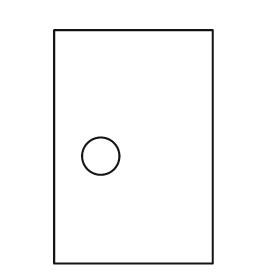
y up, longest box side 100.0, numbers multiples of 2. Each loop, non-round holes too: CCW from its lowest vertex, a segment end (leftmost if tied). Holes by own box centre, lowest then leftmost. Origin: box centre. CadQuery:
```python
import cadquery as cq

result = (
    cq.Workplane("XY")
    .moveTo(-34.0, -50.0)
    .lineTo(34.0, -50.0)
    .lineTo(34.0, 50.0)
    .lineTo(-34.0, 50.0)
    .close()
    .moveTo(-14.0, -4.0)
    .circle(8.0)
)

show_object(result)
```